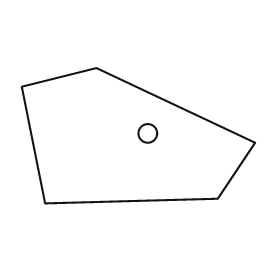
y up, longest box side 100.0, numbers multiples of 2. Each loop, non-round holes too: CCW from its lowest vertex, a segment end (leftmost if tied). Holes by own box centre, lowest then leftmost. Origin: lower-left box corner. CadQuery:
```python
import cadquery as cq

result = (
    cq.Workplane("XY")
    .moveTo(10.0, 0.0)
    .lineTo(84.0, 2.0)
    .lineTo(100.0, 26.0)
    .lineTo(32.0, 58.0)
    .lineTo(0.0, 50.0)
    .close()
    .moveTo(54.0, 30.0)
    .circle(4.0)
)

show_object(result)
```